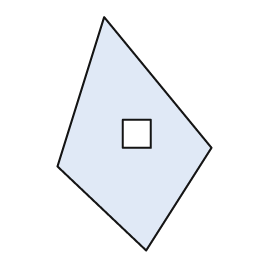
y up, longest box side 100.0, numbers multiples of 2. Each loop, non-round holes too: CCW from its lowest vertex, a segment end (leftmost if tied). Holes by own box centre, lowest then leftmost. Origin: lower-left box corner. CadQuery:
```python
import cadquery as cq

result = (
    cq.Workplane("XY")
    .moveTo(38.0, 0.0)
    .lineTo(66.0, 44.0)
    .lineTo(20.0, 100.0)
    .lineTo(0.0, 36.0)
    .close()
    .moveTo(28.0, 44.0)
    .lineTo(40.0, 44.0)
    .lineTo(40.0, 56.0)
    .lineTo(28.0, 56.0)
    .close()
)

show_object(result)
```